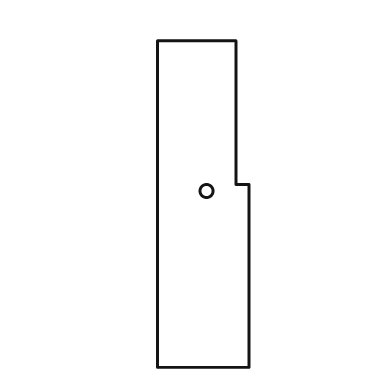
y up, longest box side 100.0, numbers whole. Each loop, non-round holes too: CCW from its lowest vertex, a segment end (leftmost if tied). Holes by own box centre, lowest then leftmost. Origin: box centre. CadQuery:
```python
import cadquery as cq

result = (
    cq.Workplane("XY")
    .moveTo(-14.0, -50.0)
    .lineTo(14.0, -50.0)
    .lineTo(14.0, 6.0)
    .lineTo(10.0, 6.0)
    .lineTo(10.0, 50.0)
    .lineTo(-14.0, 50.0)
    .close()
    .moveTo(1.0, 4.0)
    .circle(2.0)
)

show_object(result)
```